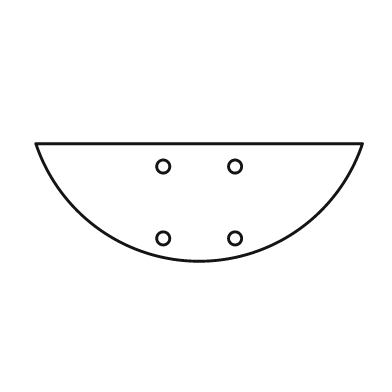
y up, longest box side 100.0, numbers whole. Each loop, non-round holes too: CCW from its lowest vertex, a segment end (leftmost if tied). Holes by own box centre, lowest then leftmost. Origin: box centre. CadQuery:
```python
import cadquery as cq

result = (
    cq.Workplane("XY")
    .moveTo(-50.0, 18.0)
    .threePointArc((0.0, -18.0), (50.0, 18.0))
    .close()
    .moveTo(-11.0, -11.0)
    .circle(2.0)
    .moveTo(11.0, -11.0)
    .circle(2.0)
    .moveTo(-11.0, 11.0)
    .circle(2.0)
    .moveTo(11.0, 11.0)
    .circle(2.0)
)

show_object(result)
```